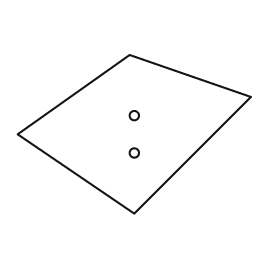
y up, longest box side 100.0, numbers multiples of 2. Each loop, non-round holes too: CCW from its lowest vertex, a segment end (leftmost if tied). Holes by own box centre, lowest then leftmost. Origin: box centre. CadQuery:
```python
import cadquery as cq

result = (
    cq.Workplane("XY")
    .moveTo(0.0, -34.0)
    .lineTo(50.0, 16.0)
    .lineTo(-2.0, 34.0)
    .lineTo(-50.0, 0.0)
    .close()
    .moveTo(0.0, -8.0)
    .circle(2.0)
    .moveTo(0.0, 8.0)
    .circle(2.0)
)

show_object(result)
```